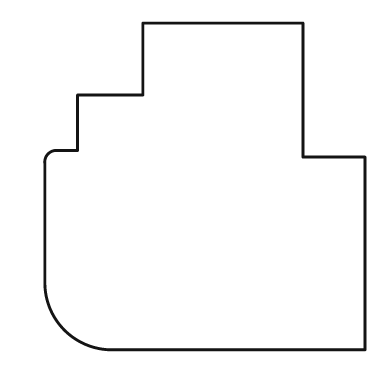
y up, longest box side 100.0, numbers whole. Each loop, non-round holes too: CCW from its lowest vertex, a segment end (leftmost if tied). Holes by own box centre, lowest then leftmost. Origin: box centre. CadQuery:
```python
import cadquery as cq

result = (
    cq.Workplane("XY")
    .moveTo(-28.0, -50.0)
    .lineTo(49.0, -50.0)
    .lineTo(49.0, 9.0)
    .lineTo(30.0, 9.0)
    .lineTo(30.0, 50.0)
    .lineTo(-19.0, 50.0)
    .lineTo(-19.0, 28.0)
    .lineTo(-39.0, 28.0)
    .lineTo(-39.0, 11.0)
    .lineTo(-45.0, 11.0)
    .threePointArc((-48.0, 10.0), (-49.0, 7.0))
    .lineTo(-49.0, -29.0)
    .threePointArc((-43.0, -44.0), (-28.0, -50.0))
    .close()
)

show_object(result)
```